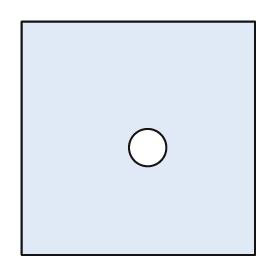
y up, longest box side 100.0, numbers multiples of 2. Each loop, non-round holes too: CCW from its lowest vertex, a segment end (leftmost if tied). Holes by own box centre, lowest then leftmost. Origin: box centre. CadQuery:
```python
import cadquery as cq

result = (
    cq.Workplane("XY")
    .moveTo(-50.0, -50.0)
    .lineTo(50.0, -50.0)
    .lineTo(50.0, 50.0)
    .lineTo(-50.0, 50.0)
    .close()
    .moveTo(4.0, -4.0)
    .circle(8.0)
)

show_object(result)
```